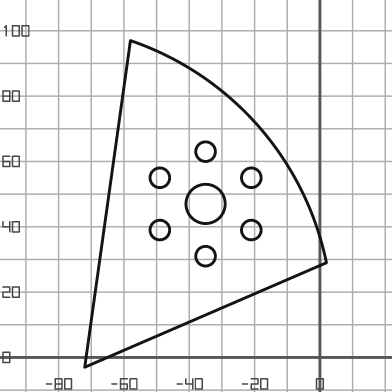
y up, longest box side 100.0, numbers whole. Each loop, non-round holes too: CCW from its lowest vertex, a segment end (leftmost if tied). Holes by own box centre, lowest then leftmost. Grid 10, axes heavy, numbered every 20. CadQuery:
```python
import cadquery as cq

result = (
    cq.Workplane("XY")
    .moveTo(-72.0, -3.0)
    .lineTo(2.0, 29.0)
    .threePointArc((-19.0, 71.0), (-58.0, 97.0))
    .close()
    .moveTo(-35.0, 31.0)
    .circle(3.0)
    .moveTo(-49.0, 39.0)
    .circle(3.0)
    .moveTo(-21.0, 39.0)
    .circle(3.0)
    .moveTo(-35.0, 47.0)
    .circle(6.0)
    .moveTo(-49.0, 55.0)
    .circle(3.0)
    .moveTo(-21.0, 55.0)
    .circle(3.0)
    .moveTo(-35.0, 63.0)
    .circle(3.0)
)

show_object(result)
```